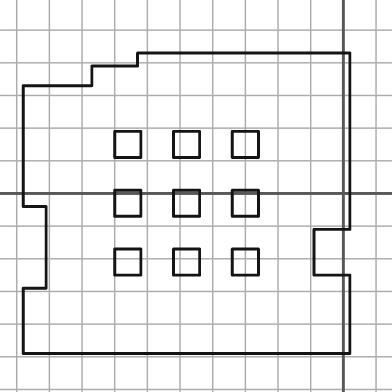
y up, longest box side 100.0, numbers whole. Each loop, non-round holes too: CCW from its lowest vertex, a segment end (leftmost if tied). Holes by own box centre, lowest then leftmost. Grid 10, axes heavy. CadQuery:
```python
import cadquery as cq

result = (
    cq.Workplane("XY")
    .moveTo(-98.0, -49.0)
    .lineTo(2.0, -49.0)
    .lineTo(2.0, -25.0)
    .lineTo(-9.0, -25.0)
    .lineTo(-9.0, -11.0)
    .lineTo(2.0, -11.0)
    .lineTo(2.0, 43.0)
    .lineTo(-63.0, 43.0)
    .lineTo(-63.0, 39.0)
    .lineTo(-77.0, 39.0)
    .lineTo(-77.0, 33.0)
    .lineTo(-98.0, 33.0)
    .lineTo(-98.0, -4.0)
    .lineTo(-91.0, -4.0)
    .lineTo(-91.0, -29.0)
    .lineTo(-98.0, -29.0)
    .close()
    .moveTo(-70.0, -25.0)
    .lineTo(-62.0, -25.0)
    .lineTo(-62.0, -17.0)
    .lineTo(-70.0, -17.0)
    .close()
    .moveTo(-52.0, -25.0)
    .lineTo(-44.0, -25.0)
    .lineTo(-44.0, -17.0)
    .lineTo(-52.0, -17.0)
    .close()
    .moveTo(-34.0, -25.0)
    .lineTo(-26.0, -25.0)
    .lineTo(-26.0, -17.0)
    .lineTo(-34.0, -17.0)
    .close()
    .moveTo(-70.0, -7.0)
    .lineTo(-62.0, -7.0)
    .lineTo(-62.0, 1.0)
    .lineTo(-70.0, 1.0)
    .close()
    .moveTo(-52.0, -7.0)
    .lineTo(-44.0, -7.0)
    .lineTo(-44.0, 1.0)
    .lineTo(-52.0, 1.0)
    .close()
    .moveTo(-34.0, -7.0)
    .lineTo(-26.0, -7.0)
    .lineTo(-26.0, 1.0)
    .lineTo(-34.0, 1.0)
    .close()
    .moveTo(-70.0, 11.0)
    .lineTo(-62.0, 11.0)
    .lineTo(-62.0, 19.0)
    .lineTo(-70.0, 19.0)
    .close()
    .moveTo(-52.0, 11.0)
    .lineTo(-44.0, 11.0)
    .lineTo(-44.0, 19.0)
    .lineTo(-52.0, 19.0)
    .close()
    .moveTo(-34.0, 11.0)
    .lineTo(-26.0, 11.0)
    .lineTo(-26.0, 19.0)
    .lineTo(-34.0, 19.0)
    .close()
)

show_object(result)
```